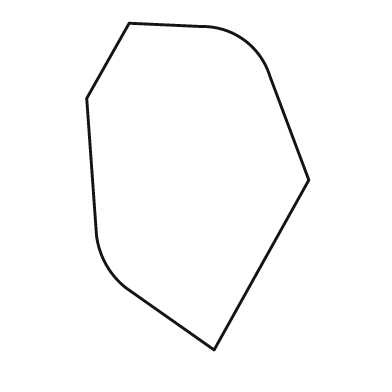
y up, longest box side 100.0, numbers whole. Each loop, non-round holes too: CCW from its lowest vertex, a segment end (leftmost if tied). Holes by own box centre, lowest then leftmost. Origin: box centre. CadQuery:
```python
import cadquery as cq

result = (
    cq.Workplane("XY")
    .moveTo(5.0, -50.0)
    .lineTo(34.0, 2.0)
    .lineTo(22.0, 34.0)
    .threePointArc((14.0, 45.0), (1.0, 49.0))
    .lineTo(-21.0, 50.0)
    .lineTo(-34.0, 27.0)
    .lineTo(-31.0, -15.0)
    .threePointArc((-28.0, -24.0), (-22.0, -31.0))
    .close()
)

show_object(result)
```